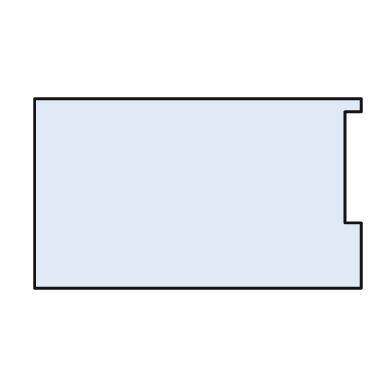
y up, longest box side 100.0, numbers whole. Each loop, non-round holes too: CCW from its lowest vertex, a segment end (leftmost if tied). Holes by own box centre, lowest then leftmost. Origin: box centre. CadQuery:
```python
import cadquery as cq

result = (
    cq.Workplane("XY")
    .moveTo(-50.0, -29.0)
    .lineTo(50.0, -29.0)
    .lineTo(50.0, -9.0)
    .lineTo(45.0, -9.0)
    .lineTo(45.0, 25.0)
    .lineTo(50.0, 25.0)
    .lineTo(50.0, 29.0)
    .lineTo(-50.0, 29.0)
    .close()
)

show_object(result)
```